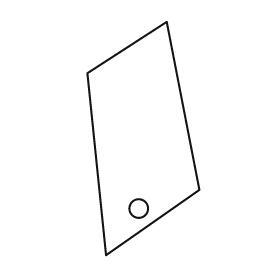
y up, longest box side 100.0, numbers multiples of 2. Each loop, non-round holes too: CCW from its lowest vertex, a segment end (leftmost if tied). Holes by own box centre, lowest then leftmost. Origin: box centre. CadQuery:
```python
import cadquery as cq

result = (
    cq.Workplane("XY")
    .moveTo(-16.0, -50.0)
    .lineTo(24.0, -22.0)
    .lineTo(10.0, 50.0)
    .lineTo(-24.0, 28.0)
    .close()
    .moveTo(-2.0, -30.0)
    .circle(4.0)
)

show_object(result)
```